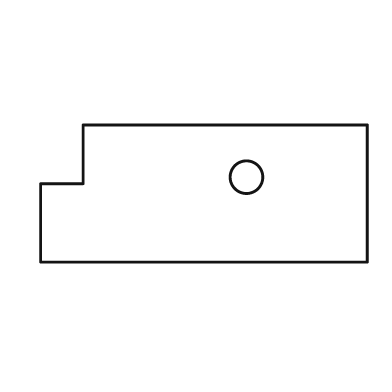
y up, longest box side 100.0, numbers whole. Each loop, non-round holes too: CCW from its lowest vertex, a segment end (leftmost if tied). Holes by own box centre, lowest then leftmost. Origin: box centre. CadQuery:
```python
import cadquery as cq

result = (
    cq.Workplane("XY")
    .moveTo(-50.0, -21.0)
    .lineTo(50.0, -21.0)
    .lineTo(50.0, 21.0)
    .lineTo(-37.0, 21.0)
    .lineTo(-37.0, 3.0)
    .lineTo(-50.0, 3.0)
    .close()
    .moveTo(13.0, 5.0)
    .circle(5.0)
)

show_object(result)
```